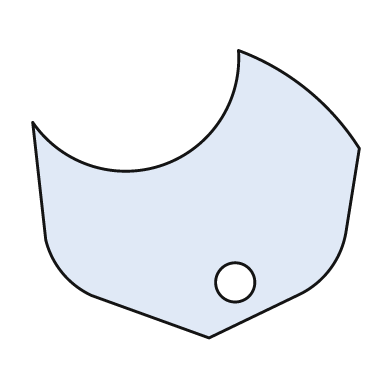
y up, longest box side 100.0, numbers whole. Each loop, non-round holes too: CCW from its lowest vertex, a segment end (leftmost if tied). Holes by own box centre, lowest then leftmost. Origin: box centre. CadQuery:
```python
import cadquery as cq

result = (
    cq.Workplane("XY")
    .moveTo(4.0, -44.0)
    .lineTo(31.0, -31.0)
    .threePointArc((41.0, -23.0), (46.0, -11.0))
    .lineTo(50.0, 14.0)
    .threePointArc((34.0, 32.0), (13.0, 44.0))
    .threePointArc((-10.0, 9.0), (-50.0, 22.0))
    .lineTo(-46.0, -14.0)
    .threePointArc((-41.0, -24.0), (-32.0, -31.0))
    .close()
    .moveTo(12.0, -27.0)
    .circle(6.0)
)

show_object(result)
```